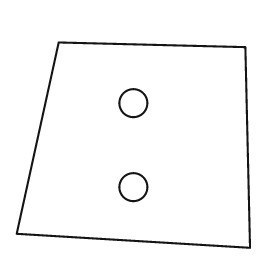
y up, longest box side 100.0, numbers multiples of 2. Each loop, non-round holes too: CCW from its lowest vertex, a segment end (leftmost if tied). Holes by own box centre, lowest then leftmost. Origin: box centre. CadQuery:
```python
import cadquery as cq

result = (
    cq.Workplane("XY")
    .moveTo(50.0, -44.0)
    .lineTo(48.0, 42.0)
    .lineTo(-32.0, 44.0)
    .lineTo(-50.0, -38.0)
    .close()
    .moveTo(0.0, -18.0)
    .circle(6.0)
    .moveTo(0.0, 18.0)
    .circle(6.0)
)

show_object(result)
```